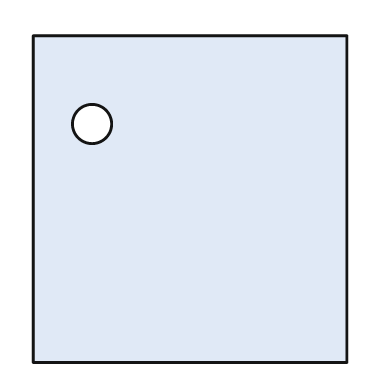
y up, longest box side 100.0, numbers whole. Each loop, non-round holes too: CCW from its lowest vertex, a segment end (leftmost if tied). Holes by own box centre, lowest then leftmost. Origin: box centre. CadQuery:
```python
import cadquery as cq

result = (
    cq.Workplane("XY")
    .moveTo(-48.0, -50.0)
    .lineTo(48.0, -50.0)
    .lineTo(48.0, 50.0)
    .lineTo(-48.0, 50.0)
    .close()
    .moveTo(-30.0, 23.0)
    .circle(6.0)
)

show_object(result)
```